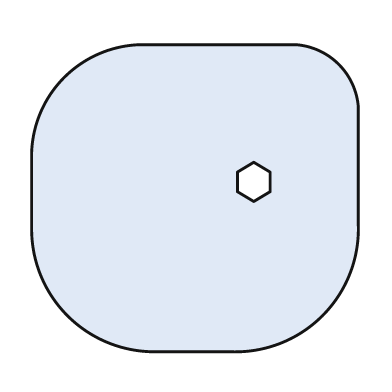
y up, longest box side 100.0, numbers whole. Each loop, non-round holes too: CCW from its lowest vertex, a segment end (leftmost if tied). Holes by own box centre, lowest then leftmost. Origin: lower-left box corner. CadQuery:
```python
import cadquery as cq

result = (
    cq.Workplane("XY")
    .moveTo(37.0, 0.0)
    .lineTo(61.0, 0.0)
    .threePointArc((89.0, 11.0), (100.0, 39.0))
    .lineTo(100.0, 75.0)
    .threePointArc((94.0, 88.0), (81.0, 94.0))
    .lineTo(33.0, 94.0)
    .threePointArc((10.0, 84.0), (0.0, 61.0))
    .lineTo(0.0, 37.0)
    .threePointArc((11.0, 11.0), (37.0, 0.0))
    .close()
    .moveTo(68.0, 46.0)
    .lineTo(73.0, 49.0)
    .lineTo(73.0, 55.0)
    .lineTo(68.0, 58.0)
    .lineTo(63.0, 55.0)
    .lineTo(63.0, 49.0)
    .close()
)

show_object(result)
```